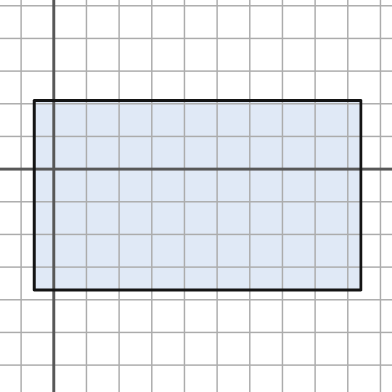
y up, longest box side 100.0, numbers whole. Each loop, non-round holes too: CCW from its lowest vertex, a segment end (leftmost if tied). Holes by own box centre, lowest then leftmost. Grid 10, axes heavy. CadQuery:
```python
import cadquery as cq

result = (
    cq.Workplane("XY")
    .moveTo(-6.0, -37.0)
    .lineTo(94.0, -37.0)
    .lineTo(94.0, 21.0)
    .lineTo(-6.0, 21.0)
    .close()
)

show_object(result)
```